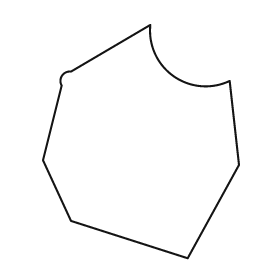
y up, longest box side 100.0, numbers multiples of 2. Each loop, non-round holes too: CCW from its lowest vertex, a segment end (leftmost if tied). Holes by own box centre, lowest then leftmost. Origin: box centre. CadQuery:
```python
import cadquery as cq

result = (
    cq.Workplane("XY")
    .moveTo(20.0, -50.0)
    .lineTo(42.0, -10.0)
    .lineTo(38.0, 26.0)
    .threePointArc((14.0, 28.0), (4.0, 50.0))
    .lineTo(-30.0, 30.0)
    .threePointArc((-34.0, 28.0), (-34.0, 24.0))
    .lineTo(-42.0, -8.0)
    .lineTo(-30.0, -34.0)
    .close()
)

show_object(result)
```